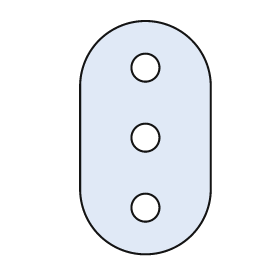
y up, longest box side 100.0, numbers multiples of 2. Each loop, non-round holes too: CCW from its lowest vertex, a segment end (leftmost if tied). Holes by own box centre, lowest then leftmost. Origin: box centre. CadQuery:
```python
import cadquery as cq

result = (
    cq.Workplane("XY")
    .moveTo(-28.0, -22.0)
    .threePointArc((0.0, -50.0), (28.0, -22.0))
    .lineTo(28.0, 22.0)
    .threePointArc((0.0, 50.0), (-28.0, 22.0))
    .close()
    .moveTo(0.0, -30.0)
    .circle(6.0)
    .moveTo(0.0, 0.0)
    .circle(6.0)
    .moveTo(0.0, 30.0)
    .circle(6.0)
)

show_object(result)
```